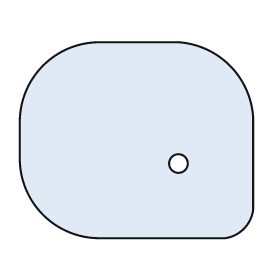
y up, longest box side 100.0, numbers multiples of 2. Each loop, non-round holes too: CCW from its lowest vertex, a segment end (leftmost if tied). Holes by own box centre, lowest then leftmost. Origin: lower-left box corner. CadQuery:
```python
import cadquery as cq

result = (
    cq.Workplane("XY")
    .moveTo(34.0, 0.0)
    .lineTo(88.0, 0.0)
    .threePointArc((96.0, 4.0), (100.0, 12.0))
    .lineTo(100.0, 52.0)
    .threePointArc((90.0, 74.0), (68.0, 84.0))
    .lineTo(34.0, 84.0)
    .threePointArc((10.0, 74.0), (0.0, 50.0))
    .lineTo(0.0, 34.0)
    .threePointArc((10.0, 10.0), (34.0, 0.0))
    .close()
    .moveTo(68.0, 32.0)
    .circle(4.0)
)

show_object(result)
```